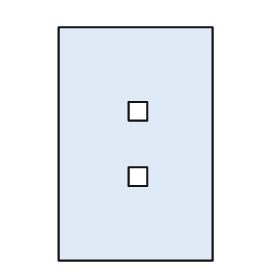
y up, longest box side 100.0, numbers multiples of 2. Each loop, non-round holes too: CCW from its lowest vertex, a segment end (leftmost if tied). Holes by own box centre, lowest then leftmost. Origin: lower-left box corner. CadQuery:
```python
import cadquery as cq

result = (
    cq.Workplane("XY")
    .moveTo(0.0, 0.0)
    .lineTo(66.0, 0.0)
    .lineTo(66.0, 100.0)
    .lineTo(0.0, 100.0)
    .close()
    .moveTo(30.0, 32.0)
    .lineTo(38.0, 32.0)
    .lineTo(38.0, 40.0)
    .lineTo(30.0, 40.0)
    .close()
    .moveTo(30.0, 60.0)
    .lineTo(38.0, 60.0)
    .lineTo(38.0, 68.0)
    .lineTo(30.0, 68.0)
    .close()
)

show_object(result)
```